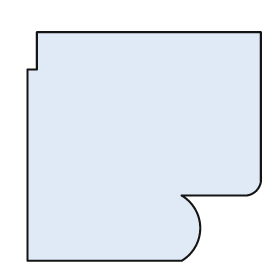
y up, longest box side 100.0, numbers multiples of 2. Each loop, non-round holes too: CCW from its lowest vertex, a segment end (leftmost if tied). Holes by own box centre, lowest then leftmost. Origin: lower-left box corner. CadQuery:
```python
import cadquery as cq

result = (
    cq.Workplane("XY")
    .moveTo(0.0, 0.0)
    .lineTo(66.0, 0.0)
    .threePointArc((74.0, 14.0), (66.0, 28.0))
    .lineTo(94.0, 28.0)
    .threePointArc((98.0, 30.0), (100.0, 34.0))
    .lineTo(100.0, 98.0)
    .lineTo(4.0, 98.0)
    .lineTo(4.0, 82.0)
    .lineTo(0.0, 82.0)
    .close()
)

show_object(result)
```